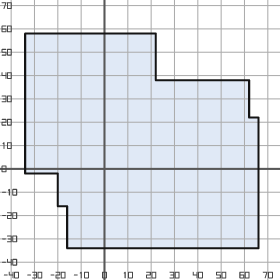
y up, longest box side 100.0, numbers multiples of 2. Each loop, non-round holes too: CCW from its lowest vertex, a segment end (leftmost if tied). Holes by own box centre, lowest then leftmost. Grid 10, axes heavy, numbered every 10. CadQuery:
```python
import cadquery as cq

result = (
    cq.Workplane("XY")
    .moveTo(-16.0, -34.0)
    .lineTo(66.0, -34.0)
    .lineTo(66.0, 22.0)
    .lineTo(62.0, 22.0)
    .lineTo(62.0, 38.0)
    .lineTo(22.0, 38.0)
    .lineTo(22.0, 58.0)
    .lineTo(-34.0, 58.0)
    .lineTo(-34.0, -2.0)
    .lineTo(-20.0, -2.0)
    .lineTo(-20.0, -16.0)
    .lineTo(-16.0, -16.0)
    .close()
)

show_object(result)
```